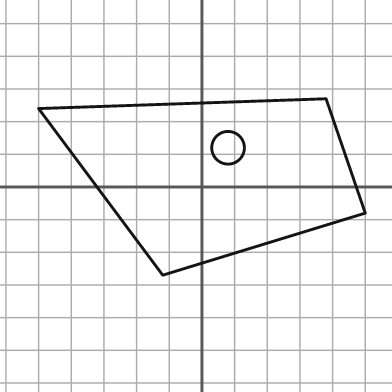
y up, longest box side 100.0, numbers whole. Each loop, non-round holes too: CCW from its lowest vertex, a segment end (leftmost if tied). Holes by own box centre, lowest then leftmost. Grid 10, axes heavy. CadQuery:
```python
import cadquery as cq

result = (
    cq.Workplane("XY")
    .moveTo(-12.0, -27.0)
    .lineTo(50.0, -8.0)
    .lineTo(38.0, 27.0)
    .lineTo(-50.0, 24.0)
    .close()
    .moveTo(8.0, 12.0)
    .circle(5.0)
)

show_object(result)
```